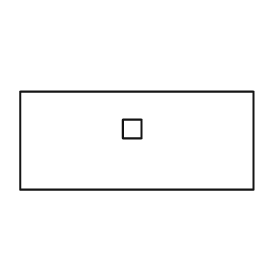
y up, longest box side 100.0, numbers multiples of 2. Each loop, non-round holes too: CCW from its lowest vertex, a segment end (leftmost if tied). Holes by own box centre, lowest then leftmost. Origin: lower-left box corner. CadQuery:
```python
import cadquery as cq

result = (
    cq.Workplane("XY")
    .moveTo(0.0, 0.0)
    .lineTo(100.0, 0.0)
    .lineTo(100.0, 42.0)
    .lineTo(0.0, 42.0)
    .close()
    .moveTo(44.0, 22.0)
    .lineTo(52.0, 22.0)
    .lineTo(52.0, 30.0)
    .lineTo(44.0, 30.0)
    .close()
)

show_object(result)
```